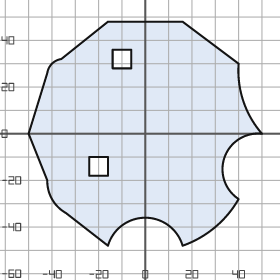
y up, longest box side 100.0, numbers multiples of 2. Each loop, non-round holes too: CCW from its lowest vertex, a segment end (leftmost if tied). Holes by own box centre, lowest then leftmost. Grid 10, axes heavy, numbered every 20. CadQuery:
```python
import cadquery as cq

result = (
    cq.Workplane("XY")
    .moveTo(-16.0, -48.0)
    .threePointArc((0.0, -36.0), (16.0, -48.0))
    .threePointArc((30.0, -40.0), (40.0, -28.0))
    .threePointArc((34.0, -10.0), (50.0, 0.0))
    .threePointArc((42.0, 14.0), (40.0, 30.0))
    .lineTo(16.0, 48.0)
    .lineTo(-16.0, 48.0)
    .lineTo(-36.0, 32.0)
    .threePointArc((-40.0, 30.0), (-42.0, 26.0))
    .lineTo(-50.0, 0.0)
    .lineTo(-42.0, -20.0)
    .threePointArc((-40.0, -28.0), (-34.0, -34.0))
    .close()
    .moveTo(-24.0, -18.0)
    .lineTo(-16.0, -18.0)
    .lineTo(-16.0, -10.0)
    .lineTo(-24.0, -10.0)
    .close()
    .moveTo(-14.0, 28.0)
    .lineTo(-6.0, 28.0)
    .lineTo(-6.0, 36.0)
    .lineTo(-14.0, 36.0)
    .close()
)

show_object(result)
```